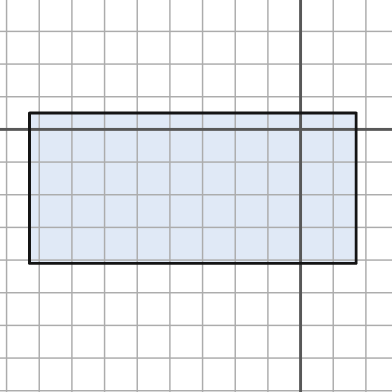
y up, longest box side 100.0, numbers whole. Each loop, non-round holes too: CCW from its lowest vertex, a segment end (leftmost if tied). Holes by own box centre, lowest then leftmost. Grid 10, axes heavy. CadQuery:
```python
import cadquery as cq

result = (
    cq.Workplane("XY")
    .moveTo(-83.0, -41.0)
    .lineTo(17.0, -41.0)
    .lineTo(17.0, 5.0)
    .lineTo(-83.0, 5.0)
    .close()
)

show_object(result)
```